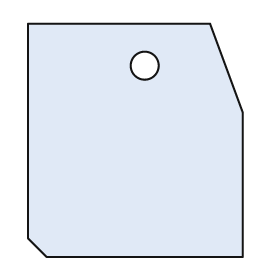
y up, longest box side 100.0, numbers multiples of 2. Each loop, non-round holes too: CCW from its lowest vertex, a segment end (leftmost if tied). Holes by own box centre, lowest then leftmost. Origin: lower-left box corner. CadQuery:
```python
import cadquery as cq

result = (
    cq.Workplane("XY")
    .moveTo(8.0, 0.0)
    .lineTo(92.0, 0.0)
    .lineTo(92.0, 62.0)
    .lineTo(78.0, 100.0)
    .lineTo(0.0, 100.0)
    .lineTo(0.0, 8.0)
    .close()
    .moveTo(50.0, 82.0)
    .circle(6.0)
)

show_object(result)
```